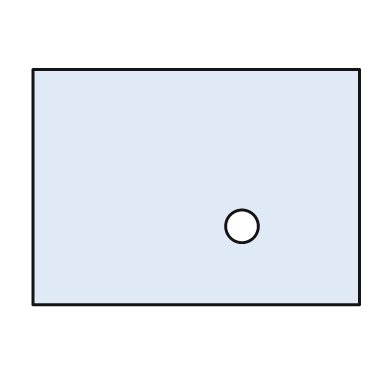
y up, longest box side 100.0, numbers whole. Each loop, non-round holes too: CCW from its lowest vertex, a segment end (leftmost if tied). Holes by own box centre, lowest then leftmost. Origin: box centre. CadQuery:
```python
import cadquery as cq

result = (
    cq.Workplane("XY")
    .moveTo(-50.0, -36.0)
    .lineTo(50.0, -36.0)
    .lineTo(50.0, 36.0)
    .lineTo(-50.0, 36.0)
    .close()
    .moveTo(14.0, -12.0)
    .circle(5.0)
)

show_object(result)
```